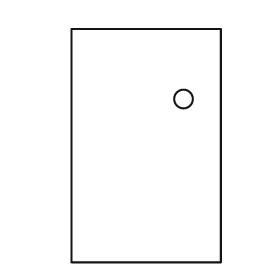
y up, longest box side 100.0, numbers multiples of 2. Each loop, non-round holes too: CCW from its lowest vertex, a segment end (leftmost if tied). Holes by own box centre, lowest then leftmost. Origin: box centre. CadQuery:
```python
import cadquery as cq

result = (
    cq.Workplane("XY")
    .moveTo(-32.0, -50.0)
    .lineTo(32.0, -50.0)
    .lineTo(32.0, 50.0)
    .lineTo(-32.0, 50.0)
    .close()
    .moveTo(16.0, 20.0)
    .circle(4.0)
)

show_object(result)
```